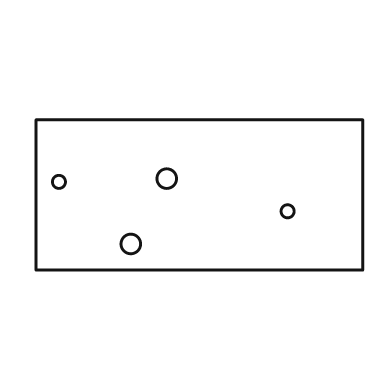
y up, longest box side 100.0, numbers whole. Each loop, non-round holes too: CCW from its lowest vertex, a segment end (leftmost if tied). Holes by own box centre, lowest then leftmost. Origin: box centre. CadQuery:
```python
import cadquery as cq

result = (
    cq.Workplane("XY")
    .moveTo(-50.0, -23.0)
    .lineTo(50.0, -23.0)
    .lineTo(50.0, 23.0)
    .lineTo(-50.0, 23.0)
    .close()
    .moveTo(-21.0, -15.0)
    .circle(3.0)
    .moveTo(27.0, -5.0)
    .circle(2.0)
    .moveTo(-43.0, 4.0)
    .circle(2.0)
    .moveTo(-10.0, 5.0)
    .circle(3.0)
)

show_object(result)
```